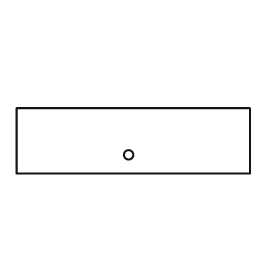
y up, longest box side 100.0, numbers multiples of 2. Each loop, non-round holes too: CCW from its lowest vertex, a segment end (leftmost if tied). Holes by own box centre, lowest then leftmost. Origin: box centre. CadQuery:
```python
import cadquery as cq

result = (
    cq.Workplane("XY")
    .moveTo(-50.0, -14.0)
    .lineTo(50.0, -14.0)
    .lineTo(50.0, 14.0)
    .lineTo(-50.0, 14.0)
    .close()
    .moveTo(-2.0, -6.0)
    .circle(2.0)
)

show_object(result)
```